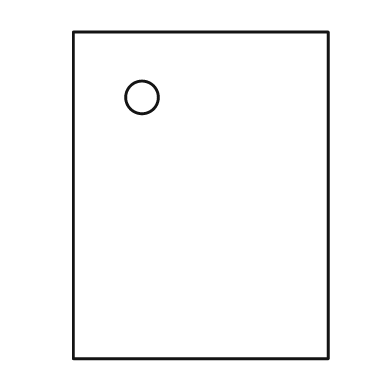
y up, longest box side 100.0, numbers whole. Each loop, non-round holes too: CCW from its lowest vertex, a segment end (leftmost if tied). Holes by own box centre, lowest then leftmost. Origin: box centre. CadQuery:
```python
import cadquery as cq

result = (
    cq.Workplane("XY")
    .moveTo(-39.0, -50.0)
    .lineTo(39.0, -50.0)
    .lineTo(39.0, 50.0)
    .lineTo(-39.0, 50.0)
    .close()
    .moveTo(-18.0, 30.0)
    .circle(5.0)
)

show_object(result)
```